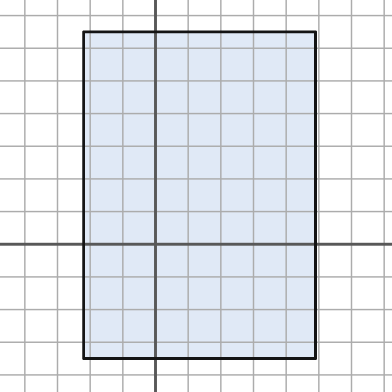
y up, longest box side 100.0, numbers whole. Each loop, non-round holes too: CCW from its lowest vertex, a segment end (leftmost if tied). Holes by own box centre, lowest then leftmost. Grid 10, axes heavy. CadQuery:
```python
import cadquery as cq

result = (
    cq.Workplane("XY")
    .moveTo(-22.0, -35.0)
    .lineTo(49.0, -35.0)
    .lineTo(49.0, 65.0)
    .lineTo(-22.0, 65.0)
    .close()
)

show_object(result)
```